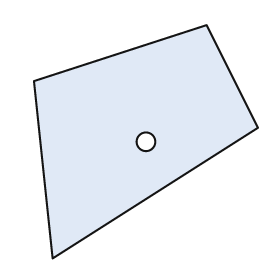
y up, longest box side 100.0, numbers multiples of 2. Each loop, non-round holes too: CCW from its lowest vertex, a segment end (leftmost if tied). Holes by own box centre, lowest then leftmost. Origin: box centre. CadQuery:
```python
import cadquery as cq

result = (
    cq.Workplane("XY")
    .moveTo(-40.0, -50.0)
    .lineTo(48.0, 6.0)
    .lineTo(26.0, 50.0)
    .lineTo(-48.0, 26.0)
    .close()
    .moveTo(0.0, 0.0)
    .circle(4.0)
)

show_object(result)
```